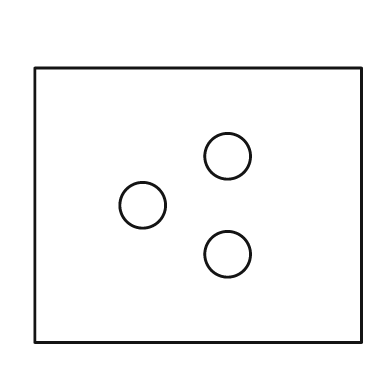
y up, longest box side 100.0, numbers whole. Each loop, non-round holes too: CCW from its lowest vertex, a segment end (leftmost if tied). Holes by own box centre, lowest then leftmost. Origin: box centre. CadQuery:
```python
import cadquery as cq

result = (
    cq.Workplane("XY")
    .moveTo(-50.0, -42.0)
    .lineTo(50.0, -42.0)
    .lineTo(50.0, 42.0)
    .lineTo(-50.0, 42.0)
    .close()
    .moveTo(9.0, -15.0)
    .circle(7.0)
    .moveTo(-17.0, 0.0)
    .circle(7.0)
    .moveTo(9.0, 15.0)
    .circle(7.0)
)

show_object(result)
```